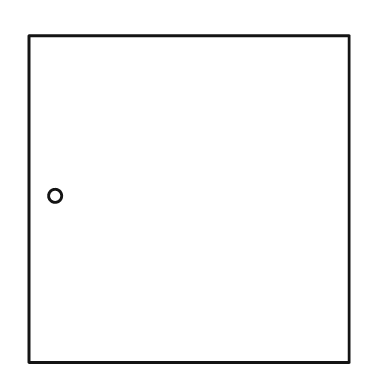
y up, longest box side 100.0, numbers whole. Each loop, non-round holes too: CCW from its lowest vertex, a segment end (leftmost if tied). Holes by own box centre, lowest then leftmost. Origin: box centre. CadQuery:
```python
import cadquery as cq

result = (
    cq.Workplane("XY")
    .moveTo(-49.0, -50.0)
    .lineTo(49.0, -50.0)
    .lineTo(49.0, 50.0)
    .lineTo(-49.0, 50.0)
    .close()
    .moveTo(-41.0, 1.0)
    .circle(2.0)
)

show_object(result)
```